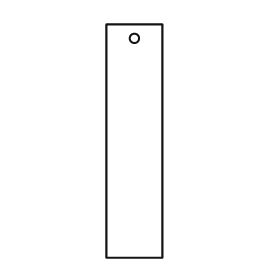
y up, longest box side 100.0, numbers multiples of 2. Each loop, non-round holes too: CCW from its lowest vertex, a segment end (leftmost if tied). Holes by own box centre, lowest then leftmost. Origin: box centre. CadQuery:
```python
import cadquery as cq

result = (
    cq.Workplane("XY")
    .moveTo(-12.0, -50.0)
    .lineTo(12.0, -50.0)
    .lineTo(12.0, 50.0)
    .lineTo(-12.0, 50.0)
    .close()
    .moveTo(0.0, 44.0)
    .circle(2.0)
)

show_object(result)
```